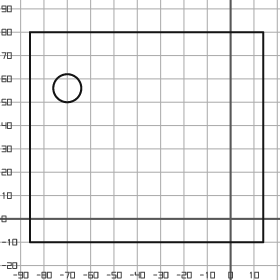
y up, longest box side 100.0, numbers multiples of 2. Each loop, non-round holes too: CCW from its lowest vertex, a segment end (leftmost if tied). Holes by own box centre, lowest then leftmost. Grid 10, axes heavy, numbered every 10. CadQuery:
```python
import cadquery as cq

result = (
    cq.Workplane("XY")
    .moveTo(-86.0, -10.0)
    .lineTo(14.0, -10.0)
    .lineTo(14.0, 80.0)
    .lineTo(-86.0, 80.0)
    .close()
    .moveTo(-70.0, 56.0)
    .circle(6.0)
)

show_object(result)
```